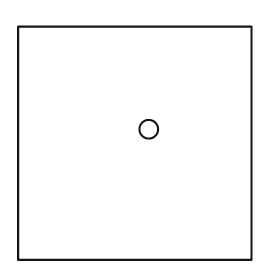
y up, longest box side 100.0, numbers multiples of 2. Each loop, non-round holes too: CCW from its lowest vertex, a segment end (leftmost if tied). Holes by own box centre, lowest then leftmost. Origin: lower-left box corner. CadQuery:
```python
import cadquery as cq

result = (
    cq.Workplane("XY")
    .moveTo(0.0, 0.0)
    .lineTo(100.0, 0.0)
    .lineTo(100.0, 100.0)
    .lineTo(0.0, 100.0)
    .close()
    .moveTo(56.0, 56.0)
    .circle(4.0)
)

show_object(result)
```